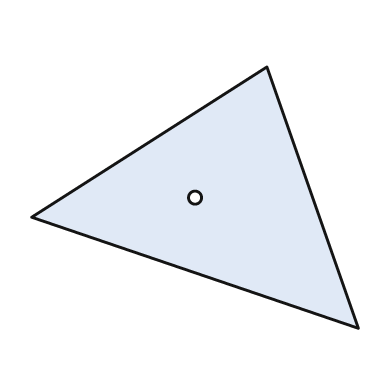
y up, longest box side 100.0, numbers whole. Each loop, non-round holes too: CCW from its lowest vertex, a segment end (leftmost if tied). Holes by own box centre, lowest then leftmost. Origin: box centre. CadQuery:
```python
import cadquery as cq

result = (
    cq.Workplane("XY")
    .moveTo(50.0, -40.0)
    .lineTo(22.0, 40.0)
    .lineTo(-50.0, -6.0)
    .close()
    .moveTo(0.0, 0.0)
    .circle(2.0)
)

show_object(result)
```